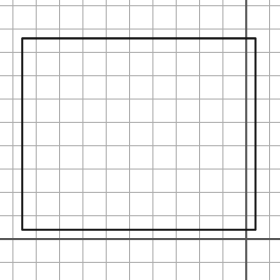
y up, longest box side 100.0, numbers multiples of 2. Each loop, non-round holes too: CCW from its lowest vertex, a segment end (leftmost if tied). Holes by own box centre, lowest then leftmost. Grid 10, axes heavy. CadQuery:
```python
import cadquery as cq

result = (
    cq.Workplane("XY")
    .moveTo(-96.0, 4.0)
    .lineTo(4.0, 4.0)
    .lineTo(4.0, 86.0)
    .lineTo(-96.0, 86.0)
    .close()
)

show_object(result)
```